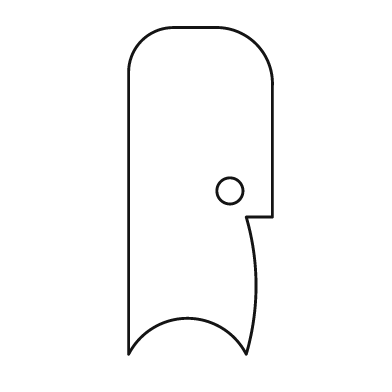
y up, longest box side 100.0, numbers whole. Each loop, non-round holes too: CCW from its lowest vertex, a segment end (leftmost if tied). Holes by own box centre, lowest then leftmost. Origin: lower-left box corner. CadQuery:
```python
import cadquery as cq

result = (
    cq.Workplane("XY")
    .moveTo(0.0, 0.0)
    .threePointArc((18.0, 11.0), (36.0, 0.0))
    .threePointArc((39.0, 21.0), (36.0, 42.0))
    .lineTo(44.0, 42.0)
    .lineTo(44.0, 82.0)
    .threePointArc((39.0, 95.0), (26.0, 100.0))
    .lineTo(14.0, 100.0)
    .threePointArc((4.0, 96.0), (0.0, 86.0))
    .close()
    .moveTo(31.0, 50.0)
    .circle(4.0)
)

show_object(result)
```